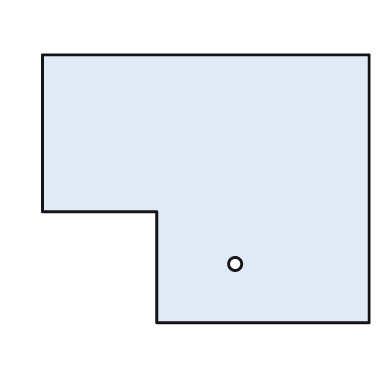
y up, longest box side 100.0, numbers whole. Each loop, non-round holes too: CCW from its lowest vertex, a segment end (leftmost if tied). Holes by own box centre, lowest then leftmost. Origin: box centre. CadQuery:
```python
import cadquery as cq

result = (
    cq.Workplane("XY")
    .moveTo(-15.0, -41.0)
    .lineTo(50.0, -41.0)
    .lineTo(50.0, 41.0)
    .lineTo(-50.0, 41.0)
    .lineTo(-50.0, -7.0)
    .lineTo(-15.0, -7.0)
    .close()
    .moveTo(9.0, -23.0)
    .circle(2.0)
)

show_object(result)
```